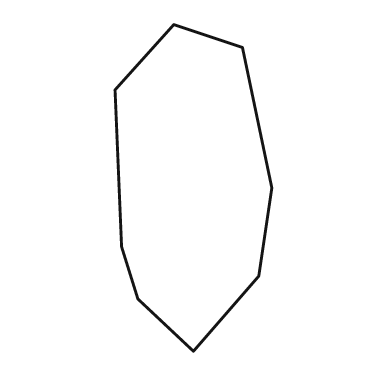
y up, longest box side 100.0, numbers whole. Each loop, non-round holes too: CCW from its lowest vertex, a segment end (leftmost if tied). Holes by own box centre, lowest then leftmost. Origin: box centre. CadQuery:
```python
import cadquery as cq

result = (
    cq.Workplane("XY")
    .moveTo(0.0, -50.0)
    .lineTo(20.0, -27.0)
    .lineTo(24.0, 0.0)
    .lineTo(15.0, 43.0)
    .lineTo(-6.0, 50.0)
    .lineTo(-24.0, 30.0)
    .lineTo(-22.0, -18.0)
    .lineTo(-17.0, -34.0)
    .close()
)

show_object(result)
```